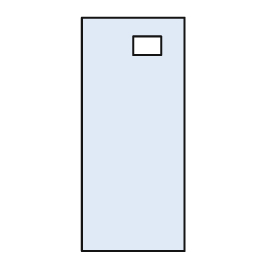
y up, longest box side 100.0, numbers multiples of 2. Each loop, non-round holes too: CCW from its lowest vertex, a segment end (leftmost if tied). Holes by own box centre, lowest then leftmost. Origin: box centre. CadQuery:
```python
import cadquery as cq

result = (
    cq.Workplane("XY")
    .moveTo(-22.0, -50.0)
    .lineTo(22.0, -50.0)
    .lineTo(22.0, 50.0)
    .lineTo(-22.0, 50.0)
    .close()
    .moveTo(0.0, 34.0)
    .lineTo(12.0, 34.0)
    .lineTo(12.0, 42.0)
    .lineTo(0.0, 42.0)
    .close()
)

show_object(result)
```